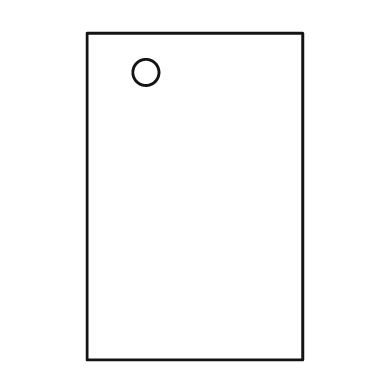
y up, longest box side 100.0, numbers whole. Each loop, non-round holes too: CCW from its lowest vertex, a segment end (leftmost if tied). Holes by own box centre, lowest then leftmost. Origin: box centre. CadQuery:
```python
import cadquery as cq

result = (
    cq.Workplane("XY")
    .moveTo(-33.0, -50.0)
    .lineTo(33.0, -50.0)
    .lineTo(33.0, 50.0)
    .lineTo(-33.0, 50.0)
    .close()
    .moveTo(-15.0, 38.0)
    .circle(4.0)
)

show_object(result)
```